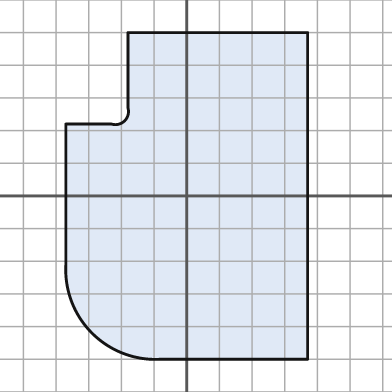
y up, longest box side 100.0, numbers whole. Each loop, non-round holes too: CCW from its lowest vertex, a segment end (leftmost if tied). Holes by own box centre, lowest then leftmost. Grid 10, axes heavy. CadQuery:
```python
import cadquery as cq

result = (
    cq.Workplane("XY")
    .moveTo(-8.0, -50.0)
    .lineTo(37.0, -50.0)
    .lineTo(37.0, 50.0)
    .lineTo(-18.0, 50.0)
    .lineTo(-18.0, 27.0)
    .threePointArc((-19.0, 23.0), (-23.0, 22.0))
    .lineTo(-37.0, 22.0)
    .lineTo(-37.0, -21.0)
    .threePointArc((-29.0, -42.0), (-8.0, -50.0))
    .close()
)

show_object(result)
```